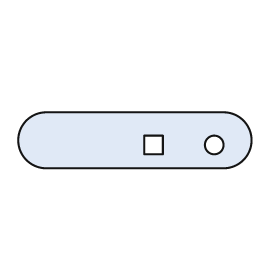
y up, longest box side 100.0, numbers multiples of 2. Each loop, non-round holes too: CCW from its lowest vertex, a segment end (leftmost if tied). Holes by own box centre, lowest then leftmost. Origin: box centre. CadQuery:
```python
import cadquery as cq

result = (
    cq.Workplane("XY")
    .moveTo(-38.0, -12.0)
    .lineTo(38.0, -12.0)
    .threePointArc((50.0, 0.0), (38.0, 12.0))
    .lineTo(-38.0, 12.0)
    .threePointArc((-50.0, 0.0), (-38.0, -12.0))
    .close()
    .moveTo(4.0, -6.0)
    .lineTo(12.0, -6.0)
    .lineTo(12.0, 2.0)
    .lineTo(4.0, 2.0)
    .close()
    .moveTo(34.0, -2.0)
    .circle(4.0)
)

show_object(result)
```